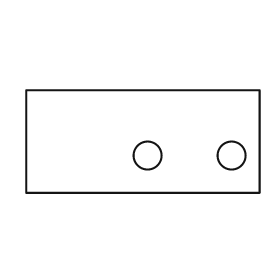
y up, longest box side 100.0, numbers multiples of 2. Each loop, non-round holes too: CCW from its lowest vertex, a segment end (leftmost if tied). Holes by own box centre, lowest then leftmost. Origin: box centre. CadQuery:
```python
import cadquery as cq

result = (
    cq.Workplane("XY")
    .moveTo(-50.0, -22.0)
    .lineTo(50.0, -22.0)
    .lineTo(50.0, 22.0)
    .lineTo(-50.0, 22.0)
    .close()
    .moveTo(2.0, -6.0)
    .circle(6.0)
    .moveTo(38.0, -6.0)
    .circle(6.0)
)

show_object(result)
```